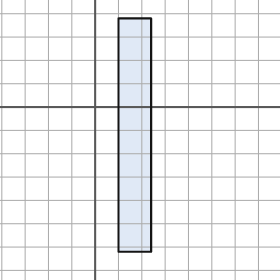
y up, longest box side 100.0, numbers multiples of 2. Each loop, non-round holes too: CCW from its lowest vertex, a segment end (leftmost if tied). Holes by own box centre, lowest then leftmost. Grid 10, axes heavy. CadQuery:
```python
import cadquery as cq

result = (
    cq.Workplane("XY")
    .moveTo(10.0, -62.0)
    .lineTo(24.0, -62.0)
    .lineTo(24.0, 38.0)
    .lineTo(10.0, 38.0)
    .close()
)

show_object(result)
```